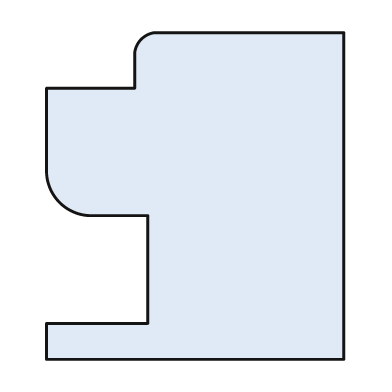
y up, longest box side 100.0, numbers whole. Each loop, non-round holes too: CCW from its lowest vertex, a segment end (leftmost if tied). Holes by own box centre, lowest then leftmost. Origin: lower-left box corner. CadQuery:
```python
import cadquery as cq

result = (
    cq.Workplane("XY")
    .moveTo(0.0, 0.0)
    .lineTo(91.0, 0.0)
    .lineTo(91.0, 100.0)
    .lineTo(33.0, 100.0)
    .threePointArc((29.0, 98.0), (27.0, 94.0))
    .lineTo(27.0, 83.0)
    .lineTo(0.0, 83.0)
    .lineTo(0.0, 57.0)
    .threePointArc((4.0, 48.0), (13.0, 44.0))
    .lineTo(31.0, 44.0)
    .lineTo(31.0, 11.0)
    .lineTo(0.0, 11.0)
    .close()
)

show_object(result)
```